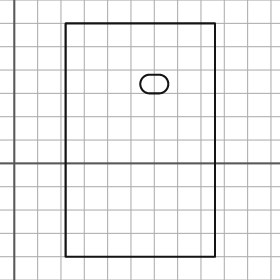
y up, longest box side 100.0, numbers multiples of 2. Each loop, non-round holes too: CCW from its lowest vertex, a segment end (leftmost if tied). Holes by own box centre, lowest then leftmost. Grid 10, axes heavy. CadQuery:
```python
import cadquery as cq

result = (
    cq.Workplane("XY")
    .moveTo(22.0, -40.0)
    .lineTo(86.0, -40.0)
    .lineTo(86.0, 60.0)
    .lineTo(22.0, 60.0)
    .close()
    .moveTo(58.0, 30.0)
    .lineTo(62.0, 30.0)
    .threePointArc((66.0, 34.0), (62.0, 38.0))
    .lineTo(58.0, 38.0)
    .threePointArc((54.0, 34.0), (58.0, 30.0))
    .close()
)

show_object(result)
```